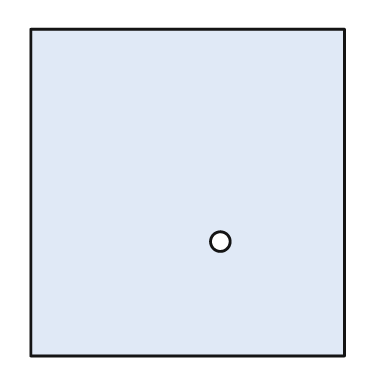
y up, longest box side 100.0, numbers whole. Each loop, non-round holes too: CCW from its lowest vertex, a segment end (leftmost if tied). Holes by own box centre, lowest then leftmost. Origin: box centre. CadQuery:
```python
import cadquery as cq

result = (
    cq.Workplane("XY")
    .moveTo(-48.0, -50.0)
    .lineTo(48.0, -50.0)
    .lineTo(48.0, 50.0)
    .lineTo(-48.0, 50.0)
    .close()
    .moveTo(10.0, -15.0)
    .circle(3.0)
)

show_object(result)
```